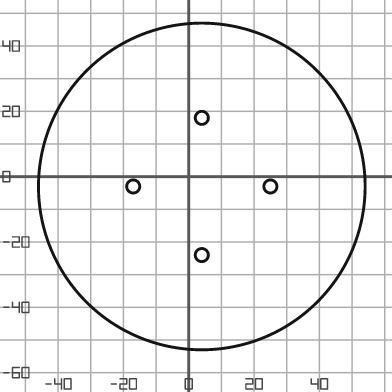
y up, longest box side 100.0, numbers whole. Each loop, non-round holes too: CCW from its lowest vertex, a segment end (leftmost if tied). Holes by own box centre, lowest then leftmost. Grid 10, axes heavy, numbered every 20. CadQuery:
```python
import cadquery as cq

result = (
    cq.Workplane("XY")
    .moveTo(4.0, -3.0)
    .circle(50.0)
    .moveTo(4.0, -24.0)
    .circle(2.0)
    .moveTo(-17.0, -3.0)
    .circle(2.0)
    .moveTo(25.0, -3.0)
    .circle(2.0)
    .moveTo(4.0, 18.0)
    .circle(2.0)
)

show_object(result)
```